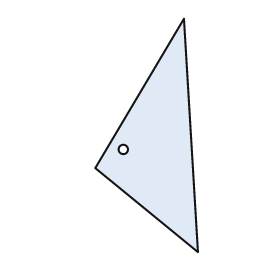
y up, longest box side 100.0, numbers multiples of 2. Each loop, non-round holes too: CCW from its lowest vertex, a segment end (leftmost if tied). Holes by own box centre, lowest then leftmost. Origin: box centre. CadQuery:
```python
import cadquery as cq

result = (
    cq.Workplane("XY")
    .moveTo(22.0, -50.0)
    .lineTo(16.0, 50.0)
    .lineTo(-22.0, -14.0)
    .close()
    .moveTo(-10.0, -6.0)
    .circle(2.0)
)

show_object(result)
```